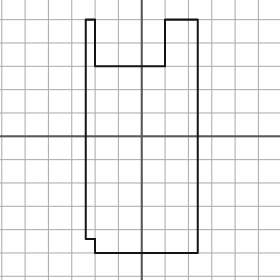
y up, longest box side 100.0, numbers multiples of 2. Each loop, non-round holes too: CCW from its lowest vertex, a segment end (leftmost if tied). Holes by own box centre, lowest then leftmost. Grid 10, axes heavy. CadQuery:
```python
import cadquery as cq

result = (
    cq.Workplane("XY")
    .moveTo(-20.0, -50.0)
    .lineTo(24.0, -50.0)
    .lineTo(24.0, 50.0)
    .lineTo(10.0, 50.0)
    .lineTo(10.0, 30.0)
    .lineTo(-20.0, 30.0)
    .lineTo(-20.0, 50.0)
    .lineTo(-24.0, 50.0)
    .lineTo(-24.0, -44.0)
    .lineTo(-20.0, -44.0)
    .close()
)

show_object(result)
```